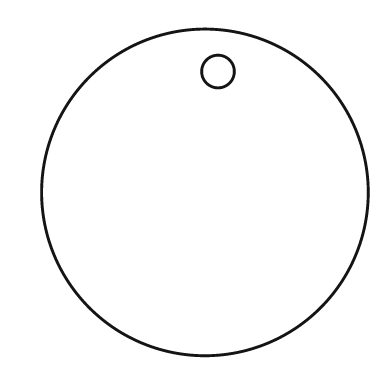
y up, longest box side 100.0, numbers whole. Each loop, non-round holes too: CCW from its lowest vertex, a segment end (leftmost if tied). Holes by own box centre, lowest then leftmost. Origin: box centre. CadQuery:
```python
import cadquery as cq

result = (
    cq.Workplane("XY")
    .moveTo(0.0, 0.0)
    .circle(50.0)
    .moveTo(4.0, 37.0)
    .circle(5.0)
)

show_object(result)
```